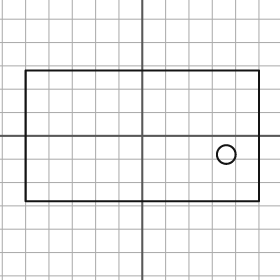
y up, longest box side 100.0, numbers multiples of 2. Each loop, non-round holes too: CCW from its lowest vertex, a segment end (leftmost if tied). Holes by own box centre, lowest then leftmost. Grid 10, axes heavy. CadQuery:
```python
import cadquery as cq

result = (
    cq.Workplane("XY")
    .moveTo(-50.0, -28.0)
    .lineTo(50.0, -28.0)
    .lineTo(50.0, 28.0)
    .lineTo(-50.0, 28.0)
    .close()
    .moveTo(36.0, -8.0)
    .circle(4.0)
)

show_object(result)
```